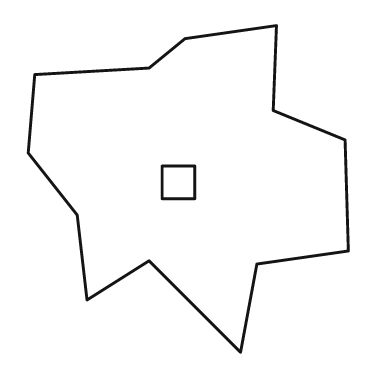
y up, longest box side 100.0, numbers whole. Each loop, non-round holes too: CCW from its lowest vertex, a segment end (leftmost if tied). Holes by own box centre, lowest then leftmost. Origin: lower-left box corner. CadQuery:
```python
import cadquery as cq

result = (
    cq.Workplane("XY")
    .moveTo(65.0, 0.0)
    .lineTo(70.0, 27.0)
    .lineTo(98.0, 31.0)
    .lineTo(97.0, 65.0)
    .lineTo(75.0, 74.0)
    .lineTo(76.0, 100.0)
    .lineTo(48.0, 96.0)
    .lineTo(37.0, 87.0)
    .lineTo(2.0, 85.0)
    .lineTo(0.0, 61.0)
    .lineTo(15.0, 42.0)
    .lineTo(18.0, 16.0)
    .lineTo(37.0, 28.0)
    .close()
    .moveTo(41.0, 47.0)
    .lineTo(51.0, 47.0)
    .lineTo(51.0, 57.0)
    .lineTo(41.0, 57.0)
    .close()
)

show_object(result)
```